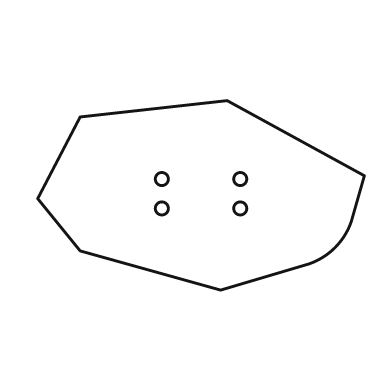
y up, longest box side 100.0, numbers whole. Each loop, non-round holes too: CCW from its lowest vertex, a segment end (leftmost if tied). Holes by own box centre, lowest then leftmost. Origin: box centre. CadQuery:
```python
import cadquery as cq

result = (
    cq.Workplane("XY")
    .moveTo(6.0, -29.0)
    .lineTo(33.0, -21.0)
    .threePointArc((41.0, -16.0), (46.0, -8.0))
    .lineTo(50.0, 6.0)
    .lineTo(8.0, 29.0)
    .lineTo(-37.0, 24.0)
    .lineTo(-50.0, -1.0)
    .lineTo(-37.0, -17.0)
    .close()
    .moveTo(-12.0, -4.0)
    .circle(2.0)
    .moveTo(12.0, -4.0)
    .circle(2.0)
    .moveTo(-12.0, 5.0)
    .circle(2.0)
    .moveTo(12.0, 5.0)
    .circle(2.0)
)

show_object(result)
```